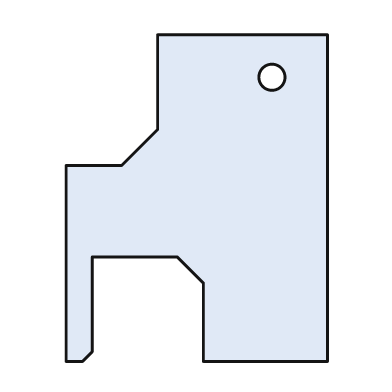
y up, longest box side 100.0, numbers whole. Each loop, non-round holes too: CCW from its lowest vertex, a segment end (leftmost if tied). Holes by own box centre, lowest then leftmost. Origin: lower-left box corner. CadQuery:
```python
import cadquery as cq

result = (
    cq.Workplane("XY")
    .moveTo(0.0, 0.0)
    .lineTo(5.0, 0.0)
    .lineTo(8.0, 3.0)
    .lineTo(8.0, 32.0)
    .lineTo(34.0, 32.0)
    .lineTo(42.0, 24.0)
    .lineTo(42.0, 0.0)
    .lineTo(80.0, 0.0)
    .lineTo(80.0, 100.0)
    .lineTo(28.0, 100.0)
    .lineTo(28.0, 71.0)
    .lineTo(17.0, 60.0)
    .lineTo(0.0, 60.0)
    .close()
    .moveTo(63.0, 87.0)
    .circle(4.0)
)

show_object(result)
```